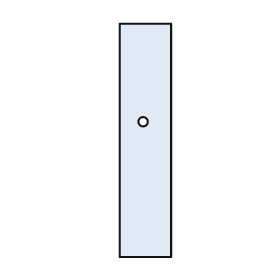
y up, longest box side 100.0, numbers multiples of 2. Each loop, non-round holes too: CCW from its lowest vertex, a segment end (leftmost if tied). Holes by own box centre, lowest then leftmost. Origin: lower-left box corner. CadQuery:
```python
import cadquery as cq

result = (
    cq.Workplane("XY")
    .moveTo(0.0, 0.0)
    .lineTo(22.0, 0.0)
    .lineTo(22.0, 100.0)
    .lineTo(0.0, 100.0)
    .close()
    .moveTo(10.0, 58.0)
    .circle(2.0)
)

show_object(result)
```